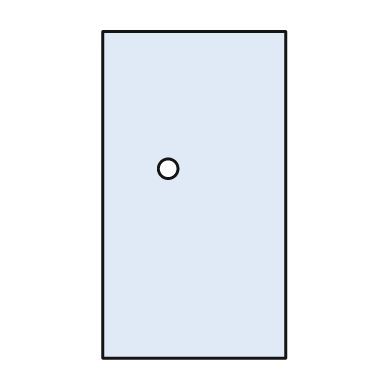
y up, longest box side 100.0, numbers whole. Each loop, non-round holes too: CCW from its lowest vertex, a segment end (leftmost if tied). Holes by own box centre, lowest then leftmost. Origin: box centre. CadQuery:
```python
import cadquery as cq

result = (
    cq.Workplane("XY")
    .moveTo(-28.0, -50.0)
    .lineTo(28.0, -50.0)
    .lineTo(28.0, 50.0)
    .lineTo(-28.0, 50.0)
    .close()
    .moveTo(-8.0, 8.0)
    .circle(3.0)
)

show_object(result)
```